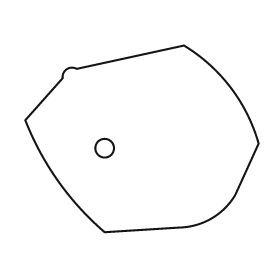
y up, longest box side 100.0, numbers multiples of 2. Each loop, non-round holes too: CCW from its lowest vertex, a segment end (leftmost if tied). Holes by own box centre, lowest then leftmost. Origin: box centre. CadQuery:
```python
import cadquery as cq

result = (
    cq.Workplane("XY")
    .moveTo(-16.0, -40.0)
    .lineTo(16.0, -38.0)
    .threePointArc((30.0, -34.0), (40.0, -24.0))
    .lineTo(50.0, -2.0)
    .threePointArc((38.0, 22.0), (18.0, 40.0))
    .lineTo(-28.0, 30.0)
    .threePointArc((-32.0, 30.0), (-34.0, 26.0))
    .lineTo(-50.0, 8.0)
    .threePointArc((-36.0, -18.0), (-16.0, -40.0))
    .close()
    .moveTo(-16.0, -4.0)
    .circle(4.0)
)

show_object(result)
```